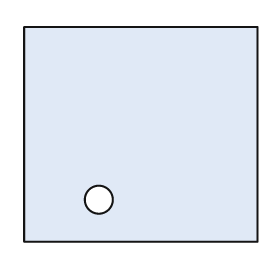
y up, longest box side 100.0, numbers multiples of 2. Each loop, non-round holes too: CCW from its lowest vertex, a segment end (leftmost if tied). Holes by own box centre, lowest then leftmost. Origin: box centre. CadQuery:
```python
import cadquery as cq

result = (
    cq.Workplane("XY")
    .moveTo(-50.0, -46.0)
    .lineTo(50.0, -46.0)
    .lineTo(50.0, 46.0)
    .lineTo(-50.0, 46.0)
    .close()
    .moveTo(-18.0, -28.0)
    .circle(6.0)
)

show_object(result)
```